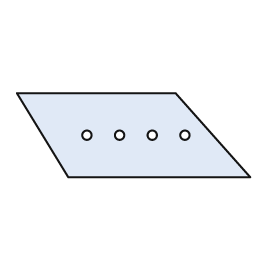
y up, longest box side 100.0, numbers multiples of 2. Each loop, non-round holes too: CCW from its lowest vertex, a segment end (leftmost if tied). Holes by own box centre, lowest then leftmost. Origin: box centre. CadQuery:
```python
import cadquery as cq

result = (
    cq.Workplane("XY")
    .moveTo(-28.0, -18.0)
    .lineTo(50.0, -18.0)
    .lineTo(18.0, 18.0)
    .lineTo(-50.0, 18.0)
    .close()
    .moveTo(-20.0, 0.0)
    .circle(2.0)
    .moveTo(-6.0, 0.0)
    .circle(2.0)
    .moveTo(8.0, 0.0)
    .circle(2.0)
    .moveTo(22.0, 0.0)
    .circle(2.0)
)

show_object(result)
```